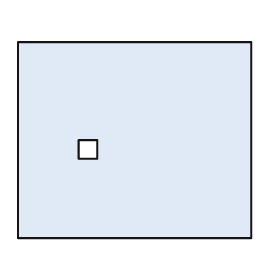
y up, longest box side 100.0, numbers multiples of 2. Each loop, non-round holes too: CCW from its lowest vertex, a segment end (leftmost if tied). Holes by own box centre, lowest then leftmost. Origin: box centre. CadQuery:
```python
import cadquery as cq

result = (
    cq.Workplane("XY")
    .moveTo(-50.0, -42.0)
    .lineTo(50.0, -42.0)
    .lineTo(50.0, 42.0)
    .lineTo(-50.0, 42.0)
    .close()
    .moveTo(-24.0, -8.0)
    .lineTo(-16.0, -8.0)
    .lineTo(-16.0, 0.0)
    .lineTo(-24.0, 0.0)
    .close()
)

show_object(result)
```